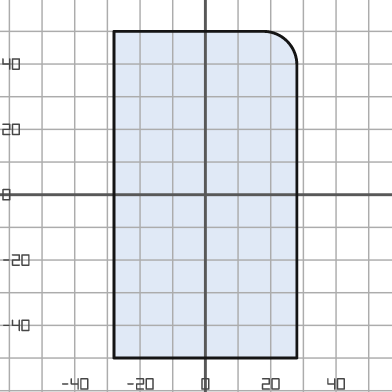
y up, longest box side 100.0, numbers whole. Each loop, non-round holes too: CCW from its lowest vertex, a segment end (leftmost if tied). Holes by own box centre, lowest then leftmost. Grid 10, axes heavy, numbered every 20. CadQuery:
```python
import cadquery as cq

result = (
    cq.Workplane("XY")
    .moveTo(-28.0, -50.0)
    .lineTo(28.0, -50.0)
    .lineTo(28.0, 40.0)
    .threePointArc((25.0, 47.0), (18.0, 50.0))
    .lineTo(-28.0, 50.0)
    .close()
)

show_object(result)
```